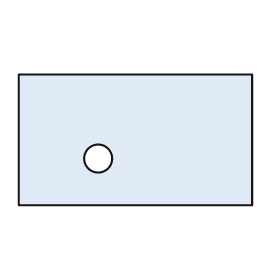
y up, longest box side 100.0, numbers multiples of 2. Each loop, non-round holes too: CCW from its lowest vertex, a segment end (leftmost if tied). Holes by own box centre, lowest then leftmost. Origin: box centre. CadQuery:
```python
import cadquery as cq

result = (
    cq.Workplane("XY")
    .moveTo(-50.0, -28.0)
    .lineTo(50.0, -28.0)
    .lineTo(50.0, 28.0)
    .lineTo(-50.0, 28.0)
    .close()
    .moveTo(-16.0, -8.0)
    .circle(6.0)
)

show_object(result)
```